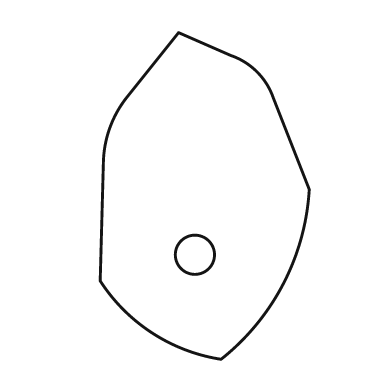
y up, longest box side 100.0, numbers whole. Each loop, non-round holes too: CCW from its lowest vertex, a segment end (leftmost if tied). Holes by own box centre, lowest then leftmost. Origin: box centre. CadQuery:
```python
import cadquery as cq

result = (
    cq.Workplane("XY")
    .moveTo(5.0, -50.0)
    .threePointArc((24.0, -27.0), (32.0, 2.0))
    .lineTo(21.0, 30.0)
    .threePointArc((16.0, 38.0), (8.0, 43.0))
    .lineTo(-8.0, 50.0)
    .lineTo(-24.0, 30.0)
    .threePointArc((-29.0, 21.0), (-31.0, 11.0))
    .lineTo(-32.0, -26.0)
    .threePointArc((-16.0, -42.0), (5.0, -50.0))
    .close()
    .moveTo(-3.0, -18.0)
    .circle(6.0)
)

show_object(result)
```